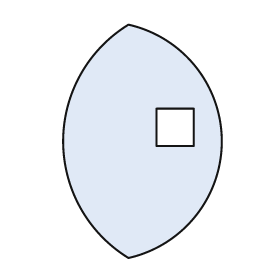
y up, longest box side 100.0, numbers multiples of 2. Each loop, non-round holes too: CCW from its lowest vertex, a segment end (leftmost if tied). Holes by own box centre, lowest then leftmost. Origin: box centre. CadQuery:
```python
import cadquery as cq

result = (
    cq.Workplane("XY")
    .moveTo(-6.0, -50.0)
    .threePointArc((34.0, 0.0), (-6.0, 50.0))
    .threePointArc((-34.0, 0.0), (-6.0, -50.0))
    .close()
    .moveTo(6.0, -2.0)
    .lineTo(22.0, -2.0)
    .lineTo(22.0, 14.0)
    .lineTo(6.0, 14.0)
    .close()
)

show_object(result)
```